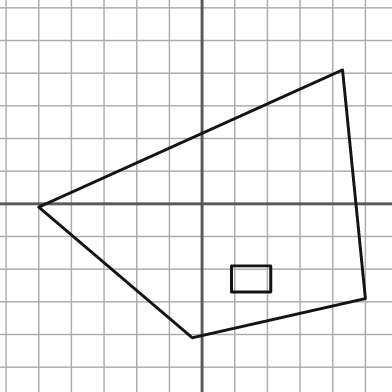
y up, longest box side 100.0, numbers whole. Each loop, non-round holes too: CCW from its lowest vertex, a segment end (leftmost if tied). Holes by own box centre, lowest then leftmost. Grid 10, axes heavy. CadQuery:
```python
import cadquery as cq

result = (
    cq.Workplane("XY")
    .moveTo(-3.0, -41.0)
    .lineTo(50.0, -29.0)
    .lineTo(43.0, 41.0)
    .lineTo(-50.0, -1.0)
    .close()
    .moveTo(9.0, -27.0)
    .lineTo(21.0, -27.0)
    .lineTo(21.0, -19.0)
    .lineTo(9.0, -19.0)
    .close()
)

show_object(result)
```